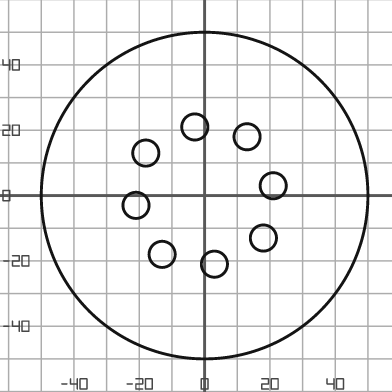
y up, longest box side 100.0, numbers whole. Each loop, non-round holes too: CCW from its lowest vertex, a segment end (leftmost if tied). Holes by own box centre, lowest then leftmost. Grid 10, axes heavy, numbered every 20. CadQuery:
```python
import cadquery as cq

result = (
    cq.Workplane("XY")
    .moveTo(0.0, 0.0)
    .circle(50.0)
    .moveTo(3.0, -21.0)
    .circle(4.0)
    .moveTo(-13.0, -18.0)
    .circle(4.0)
    .moveTo(18.0, -13.0)
    .circle(4.0)
    .moveTo(-21.0, -3.0)
    .circle(4.0)
    .moveTo(21.0, 3.0)
    .circle(4.0)
    .moveTo(-18.0, 13.0)
    .circle(4.0)
    .moveTo(13.0, 18.0)
    .circle(4.0)
    .moveTo(-3.0, 21.0)
    .circle(4.0)
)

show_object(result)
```